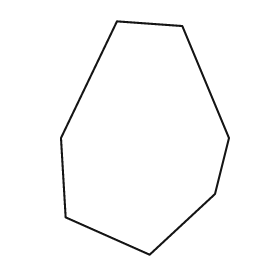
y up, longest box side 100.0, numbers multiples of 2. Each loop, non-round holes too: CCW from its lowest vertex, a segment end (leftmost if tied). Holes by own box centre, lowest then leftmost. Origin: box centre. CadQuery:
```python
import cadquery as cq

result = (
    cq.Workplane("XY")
    .moveTo(2.0, -50.0)
    .lineTo(30.0, -24.0)
    .lineTo(36.0, 0.0)
    .lineTo(16.0, 48.0)
    .lineTo(-12.0, 50.0)
    .lineTo(-36.0, 0.0)
    .lineTo(-34.0, -34.0)
    .close()
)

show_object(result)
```